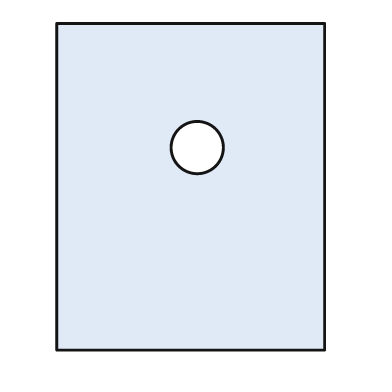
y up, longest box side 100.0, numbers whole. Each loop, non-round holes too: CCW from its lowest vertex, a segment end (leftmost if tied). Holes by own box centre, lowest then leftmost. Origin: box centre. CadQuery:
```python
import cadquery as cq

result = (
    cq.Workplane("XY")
    .moveTo(-41.0, -50.0)
    .lineTo(41.0, -50.0)
    .lineTo(41.0, 50.0)
    .lineTo(-41.0, 50.0)
    .close()
    .moveTo(2.0, 12.0)
    .circle(8.0)
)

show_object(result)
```